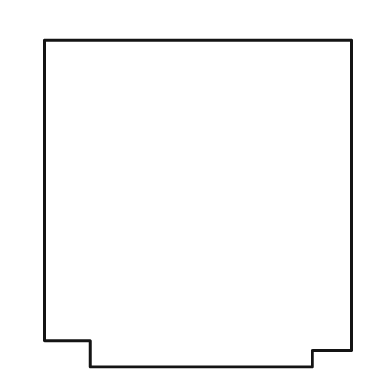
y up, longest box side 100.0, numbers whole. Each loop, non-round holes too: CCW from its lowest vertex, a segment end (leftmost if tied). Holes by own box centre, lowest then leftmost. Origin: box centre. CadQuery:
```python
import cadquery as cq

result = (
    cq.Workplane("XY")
    .moveTo(-33.0, -50.0)
    .lineTo(35.0, -50.0)
    .lineTo(35.0, -45.0)
    .lineTo(47.0, -45.0)
    .lineTo(47.0, 50.0)
    .lineTo(-47.0, 50.0)
    .lineTo(-47.0, -42.0)
    .lineTo(-33.0, -42.0)
    .close()
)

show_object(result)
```